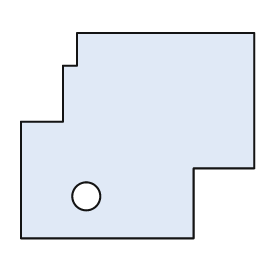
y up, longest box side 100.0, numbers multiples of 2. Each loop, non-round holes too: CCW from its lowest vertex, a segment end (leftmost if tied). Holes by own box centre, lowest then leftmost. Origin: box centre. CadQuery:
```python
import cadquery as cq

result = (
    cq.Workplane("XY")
    .moveTo(-50.0, -44.0)
    .lineTo(24.0, -44.0)
    .lineTo(24.0, -14.0)
    .lineTo(50.0, -14.0)
    .lineTo(50.0, 44.0)
    .lineTo(-26.0, 44.0)
    .lineTo(-26.0, 30.0)
    .lineTo(-32.0, 30.0)
    .lineTo(-32.0, 6.0)
    .lineTo(-50.0, 6.0)
    .close()
    .moveTo(-22.0, -26.0)
    .circle(6.0)
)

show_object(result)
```